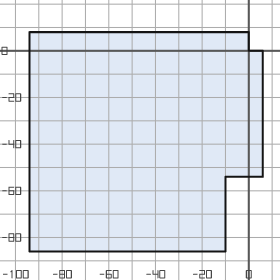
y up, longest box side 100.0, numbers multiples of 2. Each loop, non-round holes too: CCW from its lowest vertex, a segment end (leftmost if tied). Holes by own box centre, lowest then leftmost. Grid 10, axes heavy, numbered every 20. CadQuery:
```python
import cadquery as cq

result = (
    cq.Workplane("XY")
    .moveTo(-94.0, -86.0)
    .lineTo(-10.0, -86.0)
    .lineTo(-10.0, -54.0)
    .lineTo(6.0, -54.0)
    .lineTo(6.0, 0.0)
    .lineTo(0.0, 0.0)
    .lineTo(0.0, 8.0)
    .lineTo(-94.0, 8.0)
    .close()
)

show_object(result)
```